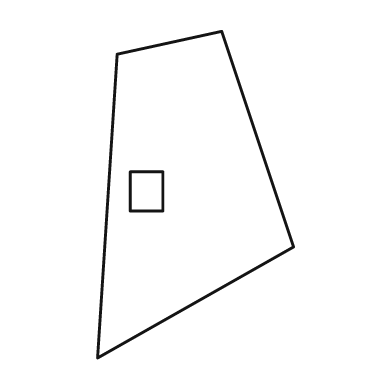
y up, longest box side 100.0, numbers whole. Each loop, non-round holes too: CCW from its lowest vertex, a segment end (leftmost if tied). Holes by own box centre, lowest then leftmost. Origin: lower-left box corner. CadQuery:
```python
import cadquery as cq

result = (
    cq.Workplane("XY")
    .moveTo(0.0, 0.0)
    .lineTo(60.0, 34.0)
    .lineTo(38.0, 100.0)
    .lineTo(6.0, 93.0)
    .close()
    .moveTo(10.0, 45.0)
    .lineTo(20.0, 45.0)
    .lineTo(20.0, 57.0)
    .lineTo(10.0, 57.0)
    .close()
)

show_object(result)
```